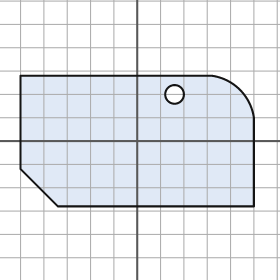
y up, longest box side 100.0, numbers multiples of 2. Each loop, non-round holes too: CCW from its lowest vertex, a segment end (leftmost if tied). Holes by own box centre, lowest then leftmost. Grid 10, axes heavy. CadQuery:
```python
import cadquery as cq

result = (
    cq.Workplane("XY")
    .moveTo(-34.0, -28.0)
    .lineTo(50.0, -28.0)
    .lineTo(50.0, 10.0)
    .threePointArc((44.0, 22.0), (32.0, 28.0))
    .lineTo(-50.0, 28.0)
    .lineTo(-50.0, -12.0)
    .close()
    .moveTo(16.0, 20.0)
    .circle(4.0)
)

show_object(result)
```